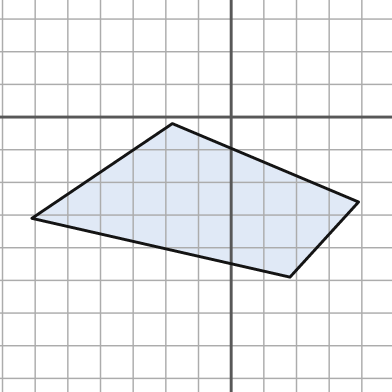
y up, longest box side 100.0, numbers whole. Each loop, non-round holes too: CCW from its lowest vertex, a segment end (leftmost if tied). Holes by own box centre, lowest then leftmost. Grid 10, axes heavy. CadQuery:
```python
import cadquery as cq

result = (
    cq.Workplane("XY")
    .moveTo(18.0, -49.0)
    .lineTo(39.0, -26.0)
    .lineTo(-18.0, -2.0)
    .lineTo(-61.0, -31.0)
    .close()
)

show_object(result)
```